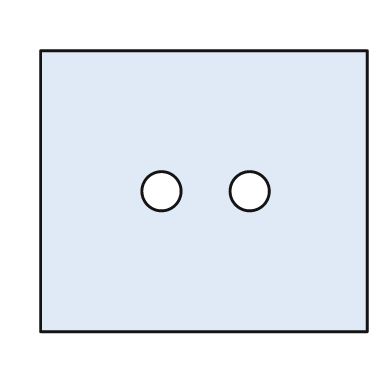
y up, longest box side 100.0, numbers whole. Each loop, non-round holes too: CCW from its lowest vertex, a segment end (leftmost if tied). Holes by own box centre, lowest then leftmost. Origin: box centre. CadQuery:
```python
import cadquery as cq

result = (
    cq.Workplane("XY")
    .moveTo(-50.0, -43.0)
    .lineTo(50.0, -43.0)
    .lineTo(50.0, 43.0)
    .lineTo(-50.0, 43.0)
    .close()
    .moveTo(-13.0, 0.0)
    .circle(6.0)
    .moveTo(14.0, 0.0)
    .circle(6.0)
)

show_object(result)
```